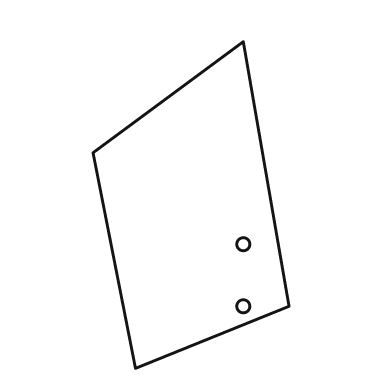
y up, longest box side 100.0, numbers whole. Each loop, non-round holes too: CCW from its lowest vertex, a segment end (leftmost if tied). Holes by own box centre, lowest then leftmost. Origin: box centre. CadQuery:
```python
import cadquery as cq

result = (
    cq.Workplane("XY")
    .moveTo(-17.0, -50.0)
    .lineTo(30.0, -31.0)
    .lineTo(16.0, 50.0)
    .lineTo(-30.0, 16.0)
    .close()
    .moveTo(16.0, -31.0)
    .circle(2.0)
    .moveTo(16.0, -12.0)
    .circle(2.0)
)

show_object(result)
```